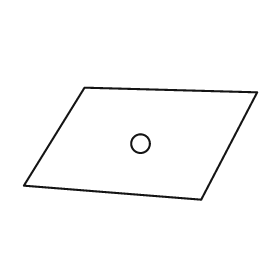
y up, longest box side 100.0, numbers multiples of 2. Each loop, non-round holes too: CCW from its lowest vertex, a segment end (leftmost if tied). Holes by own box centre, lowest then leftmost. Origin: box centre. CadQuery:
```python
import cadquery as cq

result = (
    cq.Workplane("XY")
    .moveTo(26.0, -24.0)
    .lineTo(50.0, 22.0)
    .lineTo(-24.0, 24.0)
    .lineTo(-50.0, -18.0)
    .close()
    .moveTo(0.0, 0.0)
    .circle(4.0)
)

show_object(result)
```